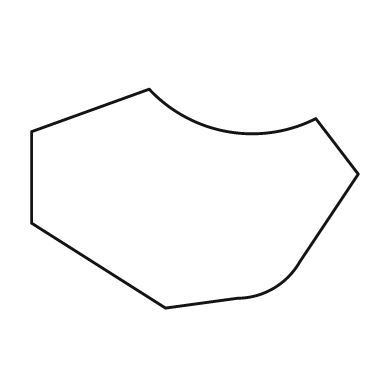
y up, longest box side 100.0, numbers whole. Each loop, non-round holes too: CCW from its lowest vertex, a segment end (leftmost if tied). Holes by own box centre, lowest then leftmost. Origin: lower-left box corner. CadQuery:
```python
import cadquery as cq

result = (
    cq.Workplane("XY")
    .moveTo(41.0, 0.0)
    .lineTo(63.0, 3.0)
    .threePointArc((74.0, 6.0), (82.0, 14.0))
    .lineTo(100.0, 41.0)
    .lineTo(87.0, 58.0)
    .threePointArc((60.0, 54.0), (36.0, 67.0))
    .lineTo(0.0, 54.0)
    .lineTo(0.0, 26.0)
    .close()
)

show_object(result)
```